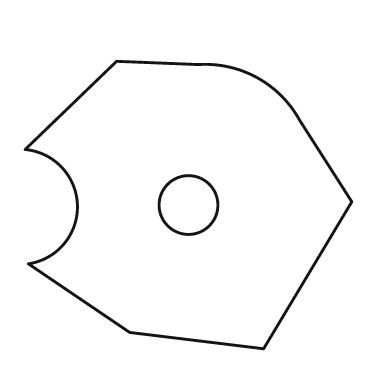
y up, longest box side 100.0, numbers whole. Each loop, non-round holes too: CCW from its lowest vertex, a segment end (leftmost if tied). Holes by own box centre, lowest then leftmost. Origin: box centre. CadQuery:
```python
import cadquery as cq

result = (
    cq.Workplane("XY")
    .moveTo(23.0, -44.0)
    .lineTo(50.0, 1.0)
    .lineTo(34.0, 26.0)
    .threePointArc((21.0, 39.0), (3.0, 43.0))
    .lineTo(-22.0, 44.0)
    .lineTo(-50.0, 17.0)
    .threePointArc((-34.0, 0.0), (-49.0, -18.0))
    .lineTo(-18.0, -39.0)
    .close()
    .moveTo(0.0, 0.0)
    .circle(9.0)
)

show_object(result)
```